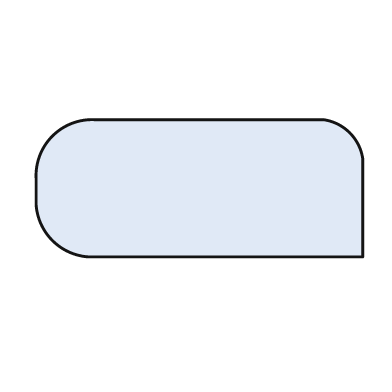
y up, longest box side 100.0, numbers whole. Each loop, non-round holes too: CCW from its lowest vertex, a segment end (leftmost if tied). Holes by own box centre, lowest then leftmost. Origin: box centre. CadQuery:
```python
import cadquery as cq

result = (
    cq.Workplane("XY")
    .moveTo(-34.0, -21.0)
    .lineTo(50.0, -21.0)
    .lineTo(50.0, 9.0)
    .threePointArc((46.0, 17.0), (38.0, 21.0))
    .lineTo(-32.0, 21.0)
    .threePointArc((-45.0, 16.0), (-50.0, 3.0))
    .lineTo(-50.0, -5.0)
    .threePointArc((-45.0, -16.0), (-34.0, -21.0))
    .close()
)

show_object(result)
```